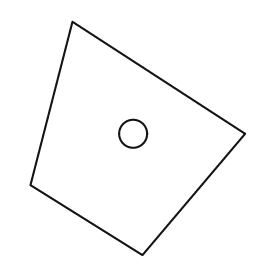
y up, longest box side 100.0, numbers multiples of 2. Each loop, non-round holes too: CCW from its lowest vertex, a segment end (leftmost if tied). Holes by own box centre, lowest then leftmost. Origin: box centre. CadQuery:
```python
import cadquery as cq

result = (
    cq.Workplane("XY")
    .moveTo(2.0, -50.0)
    .lineTo(46.0, 2.0)
    .lineTo(-28.0, 50.0)
    .lineTo(-46.0, -20.0)
    .close()
    .moveTo(-2.0, 2.0)
    .circle(6.0)
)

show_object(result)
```